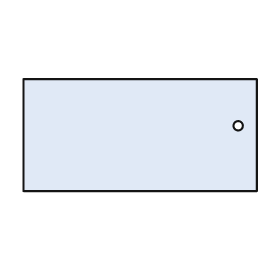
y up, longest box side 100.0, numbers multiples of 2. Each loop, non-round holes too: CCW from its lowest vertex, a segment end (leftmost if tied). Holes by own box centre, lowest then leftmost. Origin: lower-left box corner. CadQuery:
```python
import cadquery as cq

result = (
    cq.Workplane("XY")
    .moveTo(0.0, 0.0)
    .lineTo(100.0, 0.0)
    .lineTo(100.0, 48.0)
    .lineTo(0.0, 48.0)
    .close()
    .moveTo(92.0, 28.0)
    .circle(2.0)
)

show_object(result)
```